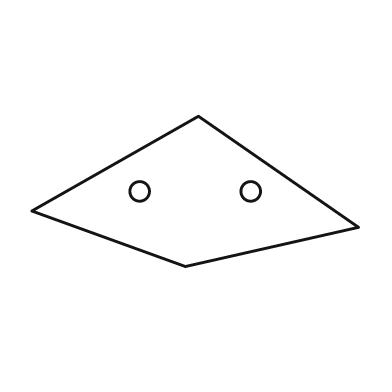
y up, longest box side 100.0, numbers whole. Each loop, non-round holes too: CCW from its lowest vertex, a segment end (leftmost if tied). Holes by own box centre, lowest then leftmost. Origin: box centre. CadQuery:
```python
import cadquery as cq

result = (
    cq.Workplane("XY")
    .moveTo(-3.0, -23.0)
    .lineTo(50.0, -11.0)
    .lineTo(1.0, 23.0)
    .lineTo(-50.0, -6.0)
    .close()
    .moveTo(-17.0, 0.0)
    .circle(3.0)
    .moveTo(17.0, 0.0)
    .circle(3.0)
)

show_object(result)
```